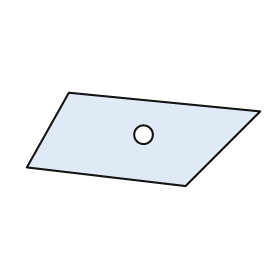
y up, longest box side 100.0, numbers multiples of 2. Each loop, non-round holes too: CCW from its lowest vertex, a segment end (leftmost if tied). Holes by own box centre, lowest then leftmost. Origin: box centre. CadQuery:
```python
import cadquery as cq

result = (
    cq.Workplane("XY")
    .moveTo(18.0, -20.0)
    .lineTo(50.0, 12.0)
    .lineTo(-32.0, 20.0)
    .lineTo(-50.0, -12.0)
    .close()
    .moveTo(0.0, 2.0)
    .circle(4.0)
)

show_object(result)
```